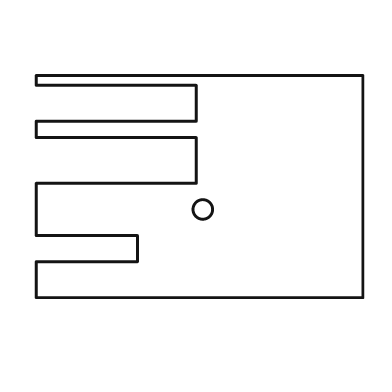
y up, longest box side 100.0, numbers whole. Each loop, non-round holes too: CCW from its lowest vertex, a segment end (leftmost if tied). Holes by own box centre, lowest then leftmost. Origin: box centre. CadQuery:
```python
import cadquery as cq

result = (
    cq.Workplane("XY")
    .moveTo(-50.0, -34.0)
    .lineTo(50.0, -34.0)
    .lineTo(50.0, 34.0)
    .lineTo(-50.0, 34.0)
    .lineTo(-50.0, 31.0)
    .lineTo(-1.0, 31.0)
    .lineTo(-1.0, 20.0)
    .lineTo(-50.0, 20.0)
    .lineTo(-50.0, 15.0)
    .lineTo(-1.0, 15.0)
    .lineTo(-1.0, 1.0)
    .lineTo(-50.0, 1.0)
    .lineTo(-50.0, -15.0)
    .lineTo(-19.0, -15.0)
    .lineTo(-19.0, -23.0)
    .lineTo(-50.0, -23.0)
    .close()
    .moveTo(1.0, -7.0)
    .circle(3.0)
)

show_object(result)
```